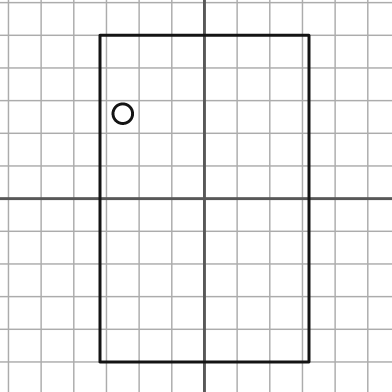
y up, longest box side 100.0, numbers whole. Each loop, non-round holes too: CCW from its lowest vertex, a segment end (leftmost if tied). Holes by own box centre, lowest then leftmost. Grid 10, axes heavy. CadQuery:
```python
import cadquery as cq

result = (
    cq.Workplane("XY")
    .moveTo(-32.0, -50.0)
    .lineTo(32.0, -50.0)
    .lineTo(32.0, 50.0)
    .lineTo(-32.0, 50.0)
    .close()
    .moveTo(-25.0, 26.0)
    .circle(3.0)
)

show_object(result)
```